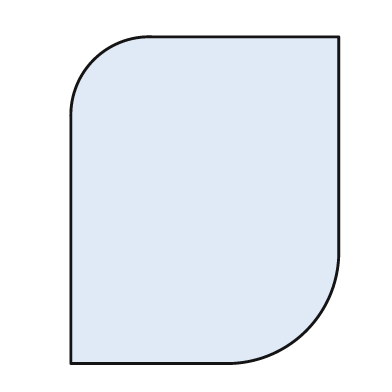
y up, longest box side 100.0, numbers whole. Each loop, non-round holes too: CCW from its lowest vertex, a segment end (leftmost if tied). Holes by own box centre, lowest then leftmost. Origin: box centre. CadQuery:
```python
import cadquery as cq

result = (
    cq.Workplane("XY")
    .moveTo(-41.0, -50.0)
    .lineTo(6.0, -50.0)
    .threePointArc((31.0, -40.0), (41.0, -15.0))
    .lineTo(41.0, 50.0)
    .lineTo(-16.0, 50.0)
    .threePointArc((-34.0, 43.0), (-41.0, 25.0))
    .close()
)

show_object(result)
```